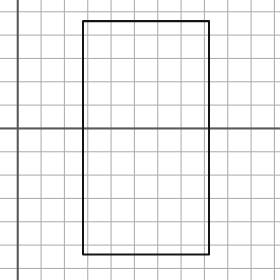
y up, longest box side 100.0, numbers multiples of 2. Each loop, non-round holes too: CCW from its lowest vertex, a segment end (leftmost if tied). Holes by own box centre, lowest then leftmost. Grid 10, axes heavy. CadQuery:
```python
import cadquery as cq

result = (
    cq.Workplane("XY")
    .moveTo(28.0, -54.0)
    .lineTo(82.0, -54.0)
    .lineTo(82.0, 46.0)
    .lineTo(28.0, 46.0)
    .close()
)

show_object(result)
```